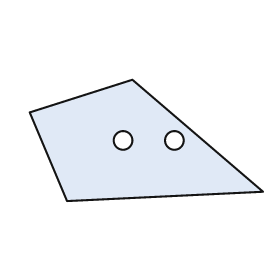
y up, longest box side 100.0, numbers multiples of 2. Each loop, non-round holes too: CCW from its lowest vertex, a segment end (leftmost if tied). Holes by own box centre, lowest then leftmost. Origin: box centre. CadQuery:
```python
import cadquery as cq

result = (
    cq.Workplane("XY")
    .moveTo(-34.0, -26.0)
    .lineTo(50.0, -22.0)
    .lineTo(-6.0, 26.0)
    .lineTo(-50.0, 12.0)
    .close()
    .moveTo(-10.0, 0.0)
    .circle(4.0)
    .moveTo(12.0, 0.0)
    .circle(4.0)
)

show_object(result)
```